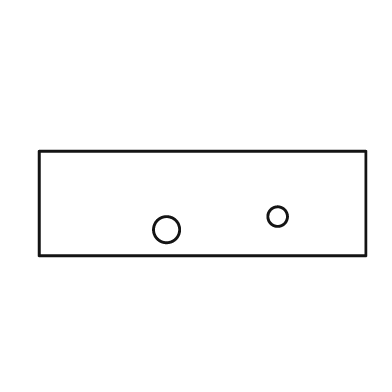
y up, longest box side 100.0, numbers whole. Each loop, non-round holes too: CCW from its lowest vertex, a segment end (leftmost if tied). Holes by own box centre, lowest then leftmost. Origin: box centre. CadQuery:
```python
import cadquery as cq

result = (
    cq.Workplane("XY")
    .moveTo(-50.0, -16.0)
    .lineTo(50.0, -16.0)
    .lineTo(50.0, 16.0)
    .lineTo(-50.0, 16.0)
    .close()
    .moveTo(-11.0, -8.0)
    .circle(4.0)
    .moveTo(23.0, -4.0)
    .circle(3.0)
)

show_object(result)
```